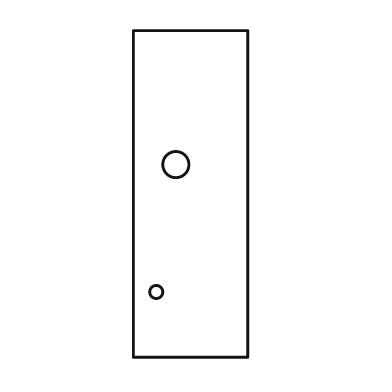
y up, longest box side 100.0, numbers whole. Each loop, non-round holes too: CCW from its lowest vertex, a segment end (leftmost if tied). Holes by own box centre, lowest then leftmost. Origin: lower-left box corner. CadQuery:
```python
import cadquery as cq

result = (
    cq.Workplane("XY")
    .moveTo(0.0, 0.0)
    .lineTo(35.0, 0.0)
    .lineTo(35.0, 100.0)
    .lineTo(0.0, 100.0)
    .close()
    .moveTo(7.0, 20.0)
    .circle(2.0)
    .moveTo(13.0, 59.0)
    .circle(4.0)
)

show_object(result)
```